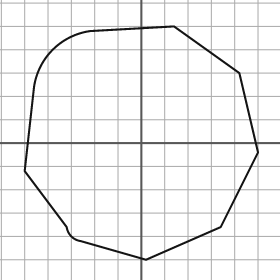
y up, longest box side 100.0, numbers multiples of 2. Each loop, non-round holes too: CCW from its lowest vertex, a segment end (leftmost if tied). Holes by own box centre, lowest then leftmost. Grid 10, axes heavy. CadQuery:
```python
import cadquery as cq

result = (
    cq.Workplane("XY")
    .moveTo(2.0, -50.0)
    .lineTo(34.0, -36.0)
    .lineTo(50.0, -4.0)
    .lineTo(42.0, 30.0)
    .lineTo(14.0, 50.0)
    .lineTo(-22.0, 48.0)
    .threePointArc((-38.0, 40.0), (-46.0, 24.0))
    .lineTo(-50.0, -12.0)
    .lineTo(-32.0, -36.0)
    .threePointArc((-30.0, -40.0), (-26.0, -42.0))
    .close()
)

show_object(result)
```